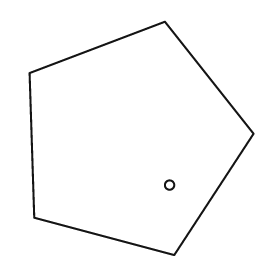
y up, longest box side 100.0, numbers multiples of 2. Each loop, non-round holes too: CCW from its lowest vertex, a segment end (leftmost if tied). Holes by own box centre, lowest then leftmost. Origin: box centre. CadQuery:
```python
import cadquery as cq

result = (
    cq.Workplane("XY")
    .moveTo(14.0, -50.0)
    .lineTo(48.0, 2.0)
    .lineTo(10.0, 50.0)
    .lineTo(-48.0, 28.0)
    .lineTo(-46.0, -34.0)
    .close()
    .moveTo(12.0, -20.0)
    .circle(2.0)
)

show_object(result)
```